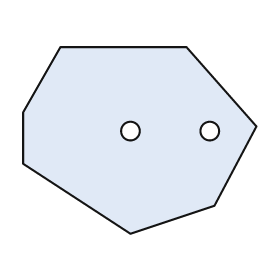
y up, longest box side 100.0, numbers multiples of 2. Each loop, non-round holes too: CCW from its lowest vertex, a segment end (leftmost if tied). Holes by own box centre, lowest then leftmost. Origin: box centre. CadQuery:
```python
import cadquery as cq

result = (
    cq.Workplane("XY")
    .moveTo(-4.0, -40.0)
    .lineTo(32.0, -28.0)
    .lineTo(50.0, 6.0)
    .lineTo(20.0, 40.0)
    .lineTo(-34.0, 40.0)
    .lineTo(-50.0, 12.0)
    .lineTo(-50.0, -10.0)
    .close()
    .moveTo(-4.0, 4.0)
    .circle(4.0)
    .moveTo(30.0, 4.0)
    .circle(4.0)
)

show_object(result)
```